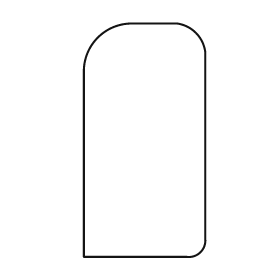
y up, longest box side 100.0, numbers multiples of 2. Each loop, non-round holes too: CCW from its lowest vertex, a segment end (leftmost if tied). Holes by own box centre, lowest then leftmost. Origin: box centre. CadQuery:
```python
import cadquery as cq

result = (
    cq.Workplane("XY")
    .moveTo(-26.0, -50.0)
    .lineTo(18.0, -50.0)
    .threePointArc((24.0, -48.0), (26.0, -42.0))
    .lineTo(26.0, 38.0)
    .threePointArc((22.0, 46.0), (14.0, 50.0))
    .lineTo(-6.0, 50.0)
    .threePointArc((-20.0, 44.0), (-26.0, 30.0))
    .close()
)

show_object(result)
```